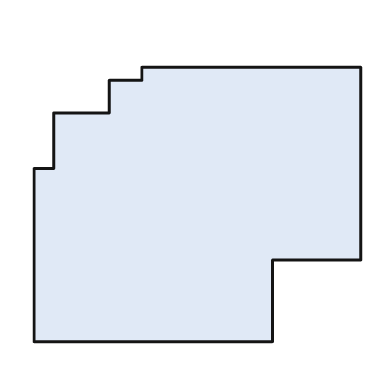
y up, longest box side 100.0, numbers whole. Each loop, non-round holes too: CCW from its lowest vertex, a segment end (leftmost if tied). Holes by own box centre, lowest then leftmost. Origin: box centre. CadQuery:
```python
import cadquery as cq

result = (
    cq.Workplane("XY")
    .moveTo(-50.0, -42.0)
    .lineTo(23.0, -42.0)
    .lineTo(23.0, -17.0)
    .lineTo(50.0, -17.0)
    .lineTo(50.0, 42.0)
    .lineTo(-17.0, 42.0)
    .lineTo(-17.0, 38.0)
    .lineTo(-27.0, 38.0)
    .lineTo(-27.0, 28.0)
    .lineTo(-44.0, 28.0)
    .lineTo(-44.0, 11.0)
    .lineTo(-50.0, 11.0)
    .close()
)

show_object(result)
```